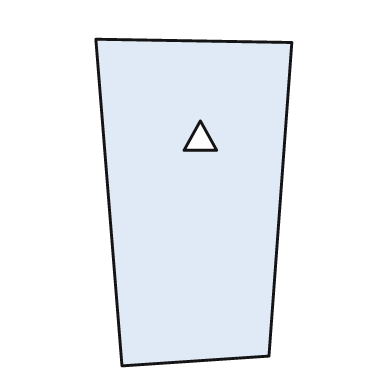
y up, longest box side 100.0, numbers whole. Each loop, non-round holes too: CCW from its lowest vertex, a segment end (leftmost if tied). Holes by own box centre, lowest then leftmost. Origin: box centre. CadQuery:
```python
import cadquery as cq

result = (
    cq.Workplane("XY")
    .moveTo(-22.0, -50.0)
    .lineTo(23.0, -47.0)
    .lineTo(30.0, 49.0)
    .lineTo(-30.0, 50.0)
    .close()
    .moveTo(-3.0, 16.0)
    .lineTo(7.0, 16.0)
    .lineTo(2.0, 25.0)
    .close()
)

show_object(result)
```